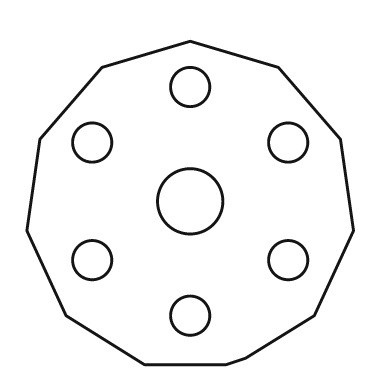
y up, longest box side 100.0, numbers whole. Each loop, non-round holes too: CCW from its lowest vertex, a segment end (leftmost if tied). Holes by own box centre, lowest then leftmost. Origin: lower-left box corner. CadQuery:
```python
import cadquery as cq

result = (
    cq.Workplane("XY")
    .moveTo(36.0, 0.0)
    .lineTo(61.0, 0.0)
    .lineTo(67.0, 2.0)
    .lineTo(88.0, 15.0)
    .lineTo(100.0, 41.0)
    .lineTo(96.0, 69.0)
    .lineTo(77.0, 91.0)
    .lineTo(50.0, 99.0)
    .lineTo(23.0, 91.0)
    .lineTo(4.0, 69.0)
    .lineTo(0.0, 41.0)
    .lineTo(12.0, 15.0)
    .close()
    .moveTo(50.0, 15.0)
    .circle(6.0)
    .moveTo(20.0, 32.0)
    .circle(6.0)
    .moveTo(80.0, 32.0)
    .circle(6.0)
    .moveTo(50.0, 50.0)
    .circle(10.0)
    .moveTo(20.0, 68.0)
    .circle(6.0)
    .moveTo(80.0, 68.0)
    .circle(6.0)
    .moveTo(50.0, 85.0)
    .circle(6.0)
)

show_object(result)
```